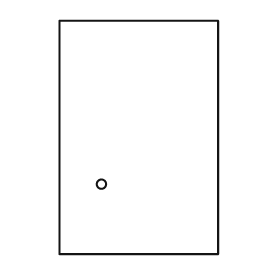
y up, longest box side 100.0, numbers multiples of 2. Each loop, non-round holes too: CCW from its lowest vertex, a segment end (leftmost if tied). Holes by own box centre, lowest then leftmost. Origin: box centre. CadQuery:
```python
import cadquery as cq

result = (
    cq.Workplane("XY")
    .moveTo(-34.0, -50.0)
    .lineTo(34.0, -50.0)
    .lineTo(34.0, 50.0)
    .lineTo(-34.0, 50.0)
    .close()
    .moveTo(-16.0, -20.0)
    .circle(2.0)
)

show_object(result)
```